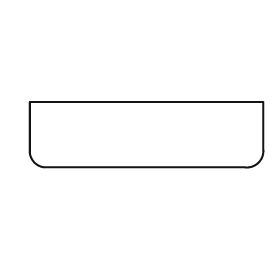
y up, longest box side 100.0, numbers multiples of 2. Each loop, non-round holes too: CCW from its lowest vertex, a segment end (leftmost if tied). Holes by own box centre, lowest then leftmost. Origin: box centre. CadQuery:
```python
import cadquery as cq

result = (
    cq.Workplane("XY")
    .moveTo(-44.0, -14.0)
    .lineTo(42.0, -14.0)
    .threePointArc((48.0, -12.0), (50.0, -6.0))
    .lineTo(50.0, 14.0)
    .lineTo(-50.0, 14.0)
    .lineTo(-50.0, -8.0)
    .threePointArc((-48.0, -12.0), (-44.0, -14.0))
    .close()
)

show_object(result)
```